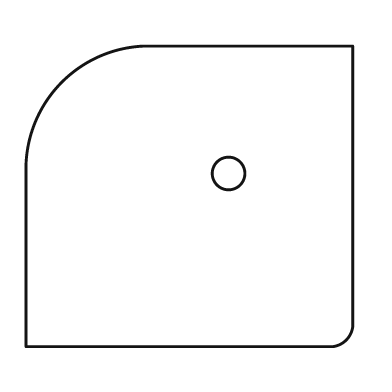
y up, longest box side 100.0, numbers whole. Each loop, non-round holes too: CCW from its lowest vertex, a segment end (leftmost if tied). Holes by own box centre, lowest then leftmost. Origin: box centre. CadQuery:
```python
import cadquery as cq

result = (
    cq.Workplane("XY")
    .moveTo(-50.0, -46.0)
    .lineTo(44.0, -46.0)
    .threePointArc((48.0, -44.0), (50.0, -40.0))
    .lineTo(50.0, 46.0)
    .lineTo(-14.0, 46.0)
    .threePointArc((-39.0, 35.0), (-50.0, 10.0))
    .close()
    .moveTo(12.0, 7.0)
    .circle(5.0)
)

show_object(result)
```